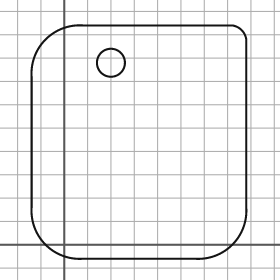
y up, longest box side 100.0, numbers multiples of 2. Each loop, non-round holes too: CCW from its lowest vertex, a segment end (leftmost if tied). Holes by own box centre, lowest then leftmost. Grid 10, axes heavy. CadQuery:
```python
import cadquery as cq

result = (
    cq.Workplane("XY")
    .moveTo(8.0, -6.0)
    .lineTo(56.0, -6.0)
    .threePointArc((72.0, 0.0), (78.0, 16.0))
    .lineTo(78.0, 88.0)
    .threePointArc((76.0, 92.0), (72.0, 94.0))
    .lineTo(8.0, 94.0)
    .threePointArc((-8.0, 88.0), (-14.0, 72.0))
    .lineTo(-14.0, 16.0)
    .threePointArc((-8.0, 0.0), (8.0, -6.0))
    .close()
    .moveTo(20.0, 78.0)
    .circle(6.0)
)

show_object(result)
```